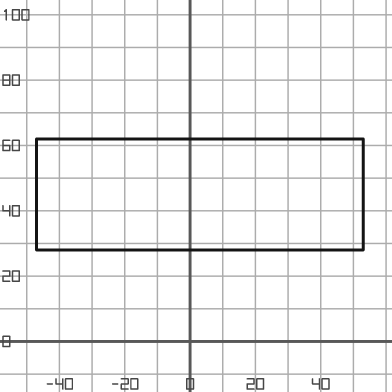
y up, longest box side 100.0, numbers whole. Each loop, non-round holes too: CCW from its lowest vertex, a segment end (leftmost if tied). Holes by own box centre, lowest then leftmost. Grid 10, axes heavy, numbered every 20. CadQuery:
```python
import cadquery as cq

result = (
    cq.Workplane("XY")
    .moveTo(-47.0, 28.0)
    .lineTo(53.0, 28.0)
    .lineTo(53.0, 62.0)
    .lineTo(-47.0, 62.0)
    .close()
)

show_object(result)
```